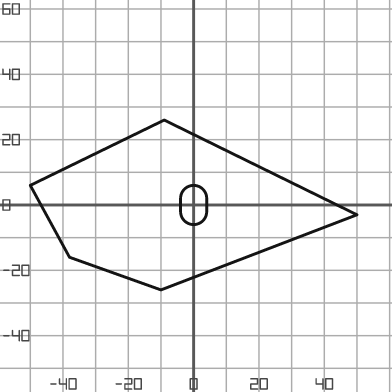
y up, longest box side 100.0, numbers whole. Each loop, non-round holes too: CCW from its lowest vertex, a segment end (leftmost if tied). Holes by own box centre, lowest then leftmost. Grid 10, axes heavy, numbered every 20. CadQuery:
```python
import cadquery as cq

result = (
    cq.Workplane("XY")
    .moveTo(-10.0, -26.0)
    .lineTo(50.0, -3.0)
    .lineTo(-9.0, 26.0)
    .lineTo(-50.0, 6.0)
    .lineTo(-38.0, -16.0)
    .close()
    .moveTo(-4.0, -2.0)
    .threePointArc((0.0, -6.0), (4.0, -2.0))
    .lineTo(4.0, 2.0)
    .threePointArc((0.0, 6.0), (-4.0, 2.0))
    .close()
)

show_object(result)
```